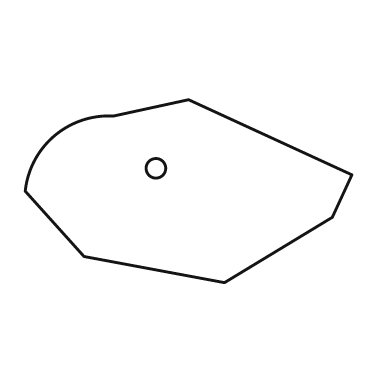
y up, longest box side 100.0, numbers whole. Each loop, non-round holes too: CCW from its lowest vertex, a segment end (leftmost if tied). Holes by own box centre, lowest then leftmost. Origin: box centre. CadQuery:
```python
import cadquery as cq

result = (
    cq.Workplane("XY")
    .moveTo(11.0, -28.0)
    .lineTo(44.0, -8.0)
    .lineTo(50.0, 5.0)
    .lineTo(0.0, 28.0)
    .lineTo(-23.0, 23.0)
    .threePointArc((-41.0, 17.0), (-50.0, 0.0))
    .lineTo(-32.0, -20.0)
    .close()
    .moveTo(-10.0, 7.0)
    .circle(3.0)
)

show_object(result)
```